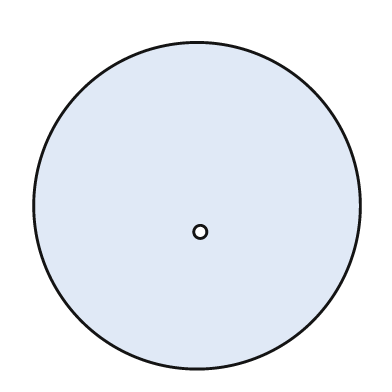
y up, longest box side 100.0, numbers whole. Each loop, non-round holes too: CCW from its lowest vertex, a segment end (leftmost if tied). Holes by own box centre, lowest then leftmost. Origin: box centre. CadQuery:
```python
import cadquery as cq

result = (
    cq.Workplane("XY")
    .moveTo(0.0, 0.0)
    .circle(50.0)
    .moveTo(1.0, -8.0)
    .circle(2.0)
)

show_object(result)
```